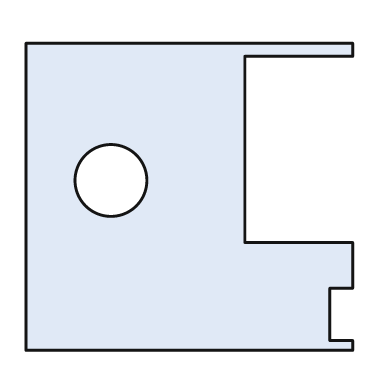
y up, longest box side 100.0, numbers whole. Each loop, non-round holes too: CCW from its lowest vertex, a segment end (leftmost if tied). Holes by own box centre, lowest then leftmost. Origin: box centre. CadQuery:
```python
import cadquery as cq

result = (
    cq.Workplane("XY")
    .moveTo(-50.0, -47.0)
    .lineTo(50.0, -47.0)
    .lineTo(50.0, -44.0)
    .lineTo(43.0, -44.0)
    .lineTo(43.0, -28.0)
    .lineTo(50.0, -28.0)
    .lineTo(50.0, -14.0)
    .lineTo(17.0, -14.0)
    .lineTo(17.0, 43.0)
    .lineTo(50.0, 43.0)
    .lineTo(50.0, 47.0)
    .lineTo(-50.0, 47.0)
    .close()
    .moveTo(-24.0, 5.0)
    .circle(11.0)
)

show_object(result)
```